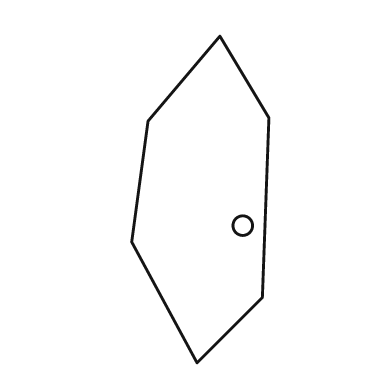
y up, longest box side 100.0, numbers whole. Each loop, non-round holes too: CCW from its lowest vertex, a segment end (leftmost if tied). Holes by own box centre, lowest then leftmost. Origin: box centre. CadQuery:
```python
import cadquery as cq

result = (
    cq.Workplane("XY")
    .moveTo(-1.0, -50.0)
    .lineTo(19.0, -30.0)
    .lineTo(21.0, 25.0)
    .lineTo(6.0, 50.0)
    .lineTo(-16.0, 24.0)
    .lineTo(-21.0, -13.0)
    .close()
    .moveTo(13.0, -8.0)
    .circle(3.0)
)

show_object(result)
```